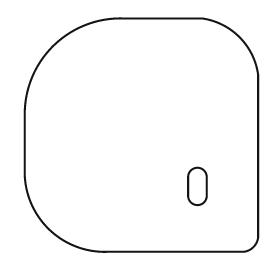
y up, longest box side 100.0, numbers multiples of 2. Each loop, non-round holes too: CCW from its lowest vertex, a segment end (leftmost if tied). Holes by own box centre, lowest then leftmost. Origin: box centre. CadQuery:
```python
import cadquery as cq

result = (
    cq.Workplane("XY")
    .moveTo(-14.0, -50.0)
    .lineTo(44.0, -50.0)
    .threePointArc((48.0, -48.0), (50.0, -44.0))
    .lineTo(50.0, 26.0)
    .threePointArc((42.0, 42.0), (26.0, 50.0))
    .lineTo(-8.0, 50.0)
    .threePointArc((-38.0, 38.0), (-50.0, 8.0))
    .lineTo(-50.0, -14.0)
    .threePointArc((-40.0, -40.0), (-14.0, -50.0))
    .close()
    .moveTo(20.0, -26.0)
    .threePointArc((24.0, -30.0), (28.0, -26.0))
    .lineTo(28.0, -18.0)
    .threePointArc((24.0, -14.0), (20.0, -18.0))
    .close()
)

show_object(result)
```